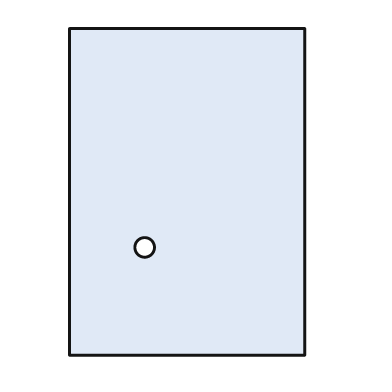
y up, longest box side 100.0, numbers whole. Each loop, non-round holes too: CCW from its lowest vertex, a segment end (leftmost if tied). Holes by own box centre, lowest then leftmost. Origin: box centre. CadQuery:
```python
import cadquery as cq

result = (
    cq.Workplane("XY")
    .moveTo(-36.0, -50.0)
    .lineTo(36.0, -50.0)
    .lineTo(36.0, 50.0)
    .lineTo(-36.0, 50.0)
    .close()
    .moveTo(-13.0, -17.0)
    .circle(3.0)
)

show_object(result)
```